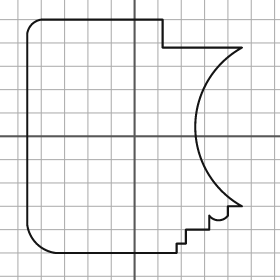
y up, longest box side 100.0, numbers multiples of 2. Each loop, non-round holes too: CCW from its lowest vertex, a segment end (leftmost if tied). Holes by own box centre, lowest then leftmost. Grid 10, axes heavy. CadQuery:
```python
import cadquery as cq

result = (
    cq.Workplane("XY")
    .moveTo(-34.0, -50.0)
    .lineTo(18.0, -50.0)
    .lineTo(18.0, -46.0)
    .lineTo(22.0, -46.0)
    .lineTo(22.0, -40.0)
    .lineTo(32.0, -40.0)
    .lineTo(32.0, -34.0)
    .threePointArc((36.0, -36.0), (40.0, -34.0))
    .lineTo(40.0, -30.0)
    .lineTo(46.0, -30.0)
    .threePointArc((26.0, 4.0), (46.0, 38.0))
    .lineTo(12.0, 38.0)
    .lineTo(12.0, 50.0)
    .lineTo(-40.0, 50.0)
    .threePointArc((-44.0, 48.0), (-46.0, 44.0))
    .lineTo(-46.0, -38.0)
    .threePointArc((-42.0, -46.0), (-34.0, -50.0))
    .close()
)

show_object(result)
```